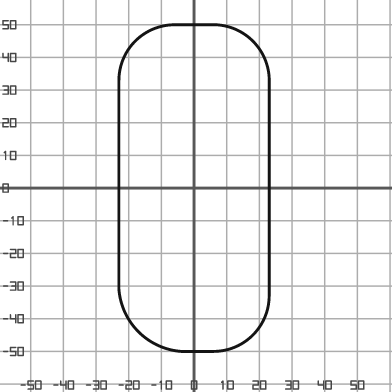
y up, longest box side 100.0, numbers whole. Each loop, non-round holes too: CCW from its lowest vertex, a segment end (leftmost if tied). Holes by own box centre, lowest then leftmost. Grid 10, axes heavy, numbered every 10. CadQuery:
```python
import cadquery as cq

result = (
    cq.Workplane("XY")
    .moveTo(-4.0, -50.0)
    .lineTo(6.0, -50.0)
    .threePointArc((18.0, -45.0), (23.0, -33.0))
    .lineTo(23.0, 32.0)
    .threePointArc((18.0, 45.0), (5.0, 50.0))
    .lineTo(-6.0, 50.0)
    .threePointArc((-18.0, 45.0), (-23.0, 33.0))
    .lineTo(-23.0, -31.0)
    .threePointArc((-17.0, -44.0), (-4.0, -50.0))
    .close()
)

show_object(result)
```